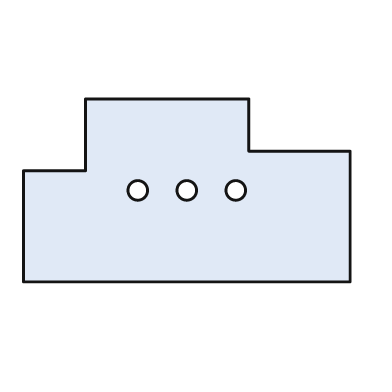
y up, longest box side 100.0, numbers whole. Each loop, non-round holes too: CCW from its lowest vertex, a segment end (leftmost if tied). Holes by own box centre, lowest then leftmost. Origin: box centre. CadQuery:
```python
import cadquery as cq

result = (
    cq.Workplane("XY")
    .moveTo(-50.0, -28.0)
    .lineTo(50.0, -28.0)
    .lineTo(50.0, 12.0)
    .lineTo(19.0, 12.0)
    .lineTo(19.0, 28.0)
    .lineTo(-31.0, 28.0)
    .lineTo(-31.0, 6.0)
    .lineTo(-50.0, 6.0)
    .close()
    .moveTo(-15.0, 0.0)
    .circle(3.0)
    .moveTo(0.0, 0.0)
    .circle(3.0)
    .moveTo(15.0, 0.0)
    .circle(3.0)
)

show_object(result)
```